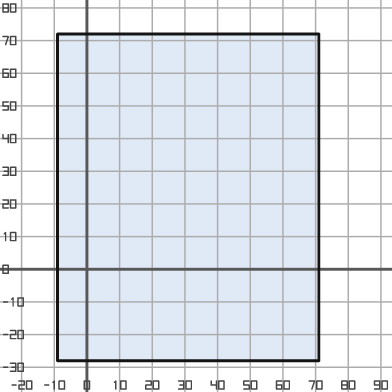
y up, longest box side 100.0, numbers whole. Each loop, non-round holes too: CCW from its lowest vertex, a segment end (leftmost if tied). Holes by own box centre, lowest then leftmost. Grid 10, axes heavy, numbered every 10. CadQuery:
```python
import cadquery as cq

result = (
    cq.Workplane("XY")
    .moveTo(-9.0, -28.0)
    .lineTo(71.0, -28.0)
    .lineTo(71.0, 72.0)
    .lineTo(-9.0, 72.0)
    .close()
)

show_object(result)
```